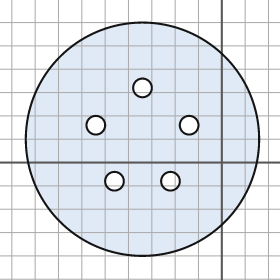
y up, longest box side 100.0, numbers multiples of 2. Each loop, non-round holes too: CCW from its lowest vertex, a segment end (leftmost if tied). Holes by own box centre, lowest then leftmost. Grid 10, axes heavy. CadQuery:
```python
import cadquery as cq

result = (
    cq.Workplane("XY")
    .moveTo(-34.0, 10.0)
    .circle(50.0)
    .moveTo(-46.0, -8.0)
    .circle(4.0)
    .moveTo(-22.0, -8.0)
    .circle(4.0)
    .moveTo(-54.0, 16.0)
    .circle(4.0)
    .moveTo(-14.0, 16.0)
    .circle(4.0)
    .moveTo(-34.0, 32.0)
    .circle(4.0)
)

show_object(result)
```